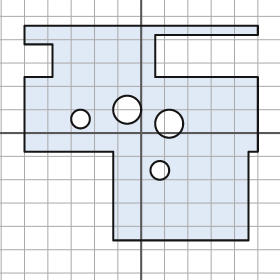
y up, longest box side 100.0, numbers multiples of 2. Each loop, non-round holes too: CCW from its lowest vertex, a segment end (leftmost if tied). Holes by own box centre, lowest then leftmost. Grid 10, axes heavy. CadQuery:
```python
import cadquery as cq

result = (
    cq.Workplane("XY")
    .moveTo(-12.0, -46.0)
    .lineTo(46.0, -46.0)
    .lineTo(46.0, -8.0)
    .lineTo(50.0, -8.0)
    .lineTo(50.0, 24.0)
    .lineTo(6.0, 24.0)
    .lineTo(6.0, 42.0)
    .lineTo(50.0, 42.0)
    .lineTo(50.0, 46.0)
    .lineTo(-50.0, 46.0)
    .lineTo(-50.0, 38.0)
    .lineTo(-38.0, 38.0)
    .lineTo(-38.0, 24.0)
    .lineTo(-50.0, 24.0)
    .lineTo(-50.0, -8.0)
    .lineTo(-12.0, -8.0)
    .close()
    .moveTo(8.0, -16.0)
    .circle(4.0)
    .moveTo(12.0, 4.0)
    .circle(6.0)
    .moveTo(-26.0, 6.0)
    .circle(4.0)
    .moveTo(-6.0, 10.0)
    .circle(6.0)
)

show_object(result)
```